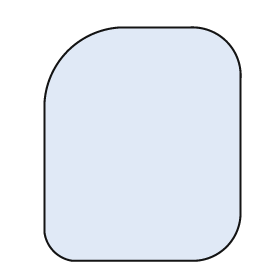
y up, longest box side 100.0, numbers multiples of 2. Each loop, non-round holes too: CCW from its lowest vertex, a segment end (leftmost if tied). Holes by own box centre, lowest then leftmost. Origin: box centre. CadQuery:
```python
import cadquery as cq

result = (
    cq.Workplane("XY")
    .moveTo(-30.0, -50.0)
    .lineTo(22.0, -50.0)
    .threePointArc((36.0, -44.0), (42.0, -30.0))
    .lineTo(42.0, 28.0)
    .threePointArc((36.0, 44.0), (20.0, 50.0))
    .lineTo(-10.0, 50.0)
    .threePointArc((-32.0, 40.0), (-42.0, 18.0))
    .lineTo(-42.0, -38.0)
    .threePointArc((-38.0, -46.0), (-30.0, -50.0))
    .close()
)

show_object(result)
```